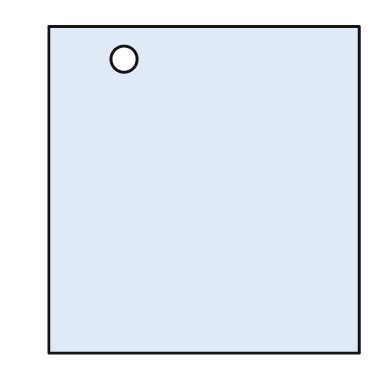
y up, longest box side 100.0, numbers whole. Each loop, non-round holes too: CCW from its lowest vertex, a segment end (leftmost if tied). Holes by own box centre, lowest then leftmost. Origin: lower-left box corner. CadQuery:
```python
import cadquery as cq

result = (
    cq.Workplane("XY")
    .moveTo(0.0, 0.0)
    .lineTo(95.0, 0.0)
    .lineTo(95.0, 100.0)
    .lineTo(0.0, 100.0)
    .close()
    .moveTo(23.0, 90.0)
    .circle(4.0)
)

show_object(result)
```